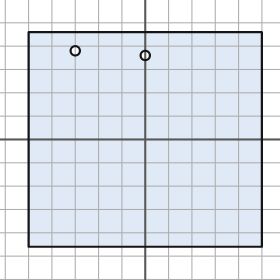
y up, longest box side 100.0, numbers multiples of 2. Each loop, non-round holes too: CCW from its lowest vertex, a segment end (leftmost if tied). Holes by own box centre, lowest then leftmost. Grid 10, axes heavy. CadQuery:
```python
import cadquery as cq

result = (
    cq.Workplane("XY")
    .moveTo(-50.0, -46.0)
    .lineTo(50.0, -46.0)
    .lineTo(50.0, 46.0)
    .lineTo(-50.0, 46.0)
    .close()
    .moveTo(0.0, 36.0)
    .circle(2.0)
    .moveTo(-30.0, 38.0)
    .circle(2.0)
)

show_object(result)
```